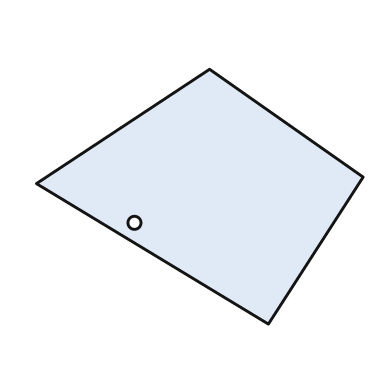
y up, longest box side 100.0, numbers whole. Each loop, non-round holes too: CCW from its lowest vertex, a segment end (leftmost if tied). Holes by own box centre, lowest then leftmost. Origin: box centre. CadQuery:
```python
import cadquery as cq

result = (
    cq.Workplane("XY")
    .moveTo(21.0, -39.0)
    .lineTo(50.0, 6.0)
    .lineTo(3.0, 39.0)
    .lineTo(-50.0, 4.0)
    .close()
    .moveTo(-20.0, -8.0)
    .circle(2.0)
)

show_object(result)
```